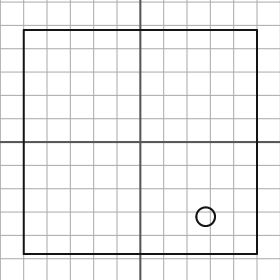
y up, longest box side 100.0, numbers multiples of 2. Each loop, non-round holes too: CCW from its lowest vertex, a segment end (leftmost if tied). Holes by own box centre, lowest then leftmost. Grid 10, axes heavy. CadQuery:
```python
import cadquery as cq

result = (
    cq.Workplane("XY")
    .moveTo(-50.0, -48.0)
    .lineTo(50.0, -48.0)
    .lineTo(50.0, 48.0)
    .lineTo(-50.0, 48.0)
    .close()
    .moveTo(28.0, -32.0)
    .circle(4.0)
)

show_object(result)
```